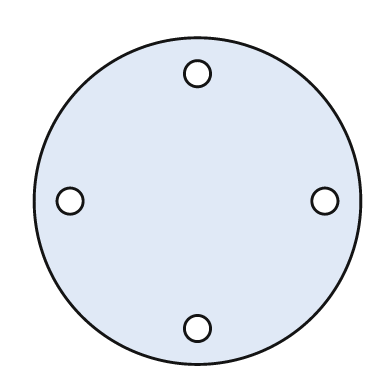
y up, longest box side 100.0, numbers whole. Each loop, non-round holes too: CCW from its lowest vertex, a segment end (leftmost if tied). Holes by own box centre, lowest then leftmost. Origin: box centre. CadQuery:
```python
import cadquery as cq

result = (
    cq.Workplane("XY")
    .moveTo(0.0, 0.0)
    .circle(50.0)
    .moveTo(0.0, -39.0)
    .circle(4.0)
    .moveTo(-39.0, 0.0)
    .circle(4.0)
    .moveTo(39.0, 0.0)
    .circle(4.0)
    .moveTo(0.0, 39.0)
    .circle(4.0)
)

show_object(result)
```